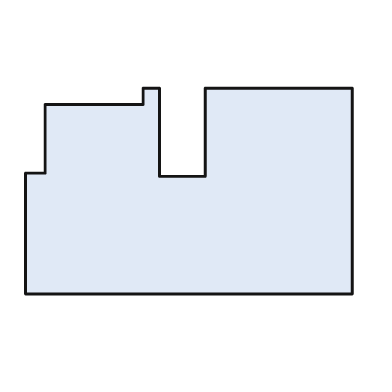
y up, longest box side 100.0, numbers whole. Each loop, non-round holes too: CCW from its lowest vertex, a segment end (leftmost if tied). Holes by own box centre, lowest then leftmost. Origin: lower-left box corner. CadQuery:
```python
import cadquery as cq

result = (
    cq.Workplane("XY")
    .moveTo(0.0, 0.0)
    .lineTo(100.0, 0.0)
    .lineTo(100.0, 63.0)
    .lineTo(55.0, 63.0)
    .lineTo(55.0, 36.0)
    .lineTo(41.0, 36.0)
    .lineTo(41.0, 63.0)
    .lineTo(36.0, 63.0)
    .lineTo(36.0, 58.0)
    .lineTo(6.0, 58.0)
    .lineTo(6.0, 37.0)
    .lineTo(0.0, 37.0)
    .close()
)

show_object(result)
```